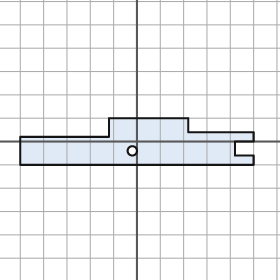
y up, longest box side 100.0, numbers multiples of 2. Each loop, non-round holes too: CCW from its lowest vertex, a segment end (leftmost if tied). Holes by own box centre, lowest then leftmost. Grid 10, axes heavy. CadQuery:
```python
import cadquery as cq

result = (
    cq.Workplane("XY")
    .moveTo(-50.0, -10.0)
    .lineTo(50.0, -10.0)
    .lineTo(50.0, -6.0)
    .lineTo(42.0, -6.0)
    .lineTo(42.0, 0.0)
    .lineTo(50.0, 0.0)
    .lineTo(50.0, 4.0)
    .lineTo(22.0, 4.0)
    .lineTo(22.0, 10.0)
    .lineTo(-12.0, 10.0)
    .lineTo(-12.0, 2.0)
    .lineTo(-50.0, 2.0)
    .close()
    .moveTo(-2.0, -4.0)
    .circle(2.0)
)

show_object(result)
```